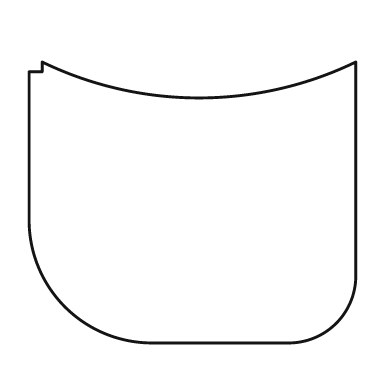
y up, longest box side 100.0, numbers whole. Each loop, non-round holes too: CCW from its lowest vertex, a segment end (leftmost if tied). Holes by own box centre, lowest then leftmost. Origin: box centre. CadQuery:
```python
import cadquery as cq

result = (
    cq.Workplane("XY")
    .moveTo(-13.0, -43.0)
    .lineTo(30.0, -43.0)
    .threePointArc((44.0, -37.0), (50.0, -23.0))
    .lineTo(50.0, 43.0)
    .threePointArc((2.0, 32.0), (-46.0, 43.0))
    .lineTo(-46.0, 40.0)
    .lineTo(-50.0, 40.0)
    .lineTo(-50.0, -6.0)
    .threePointArc((-39.0, -32.0), (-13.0, -43.0))
    .close()
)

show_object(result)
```